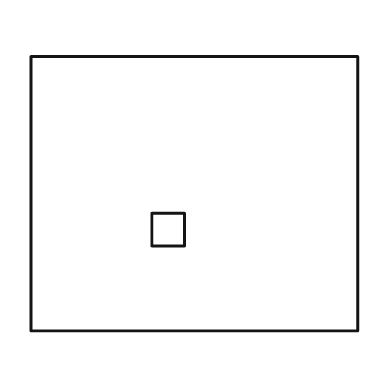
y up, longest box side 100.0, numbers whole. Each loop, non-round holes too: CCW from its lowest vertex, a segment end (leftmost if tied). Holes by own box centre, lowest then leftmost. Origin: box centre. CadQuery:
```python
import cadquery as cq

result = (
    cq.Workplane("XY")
    .moveTo(-50.0, -42.0)
    .lineTo(50.0, -42.0)
    .lineTo(50.0, 42.0)
    .lineTo(-50.0, 42.0)
    .close()
    .moveTo(-13.0, -16.0)
    .lineTo(-3.0, -16.0)
    .lineTo(-3.0, -6.0)
    .lineTo(-13.0, -6.0)
    .close()
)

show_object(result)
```